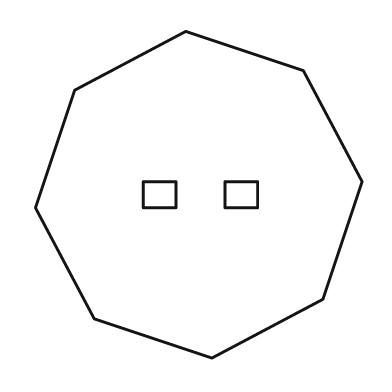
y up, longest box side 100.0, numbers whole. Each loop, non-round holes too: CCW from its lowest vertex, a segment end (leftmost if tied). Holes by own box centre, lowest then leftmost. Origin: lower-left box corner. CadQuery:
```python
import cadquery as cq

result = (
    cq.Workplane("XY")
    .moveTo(54.0, 0.0)
    .lineTo(88.0, 18.0)
    .lineTo(100.0, 54.0)
    .lineTo(82.0, 88.0)
    .lineTo(46.0, 100.0)
    .lineTo(12.0, 82.0)
    .lineTo(0.0, 46.0)
    .lineTo(18.0, 12.0)
    .close()
    .moveTo(33.0, 46.0)
    .lineTo(43.0, 46.0)
    .lineTo(43.0, 54.0)
    .lineTo(33.0, 54.0)
    .close()
    .moveTo(58.0, 46.0)
    .lineTo(68.0, 46.0)
    .lineTo(68.0, 54.0)
    .lineTo(58.0, 54.0)
    .close()
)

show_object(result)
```